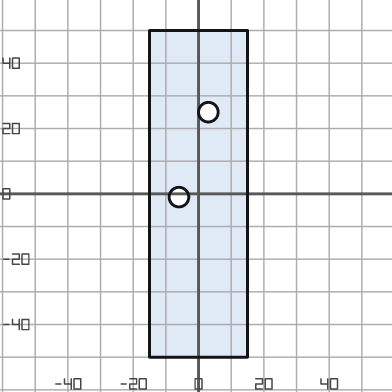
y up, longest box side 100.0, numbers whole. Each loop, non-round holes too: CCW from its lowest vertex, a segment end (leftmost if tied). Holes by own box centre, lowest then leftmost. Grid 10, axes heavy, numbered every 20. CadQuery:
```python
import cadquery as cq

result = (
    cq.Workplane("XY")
    .moveTo(-15.0, -50.0)
    .lineTo(15.0, -50.0)
    .lineTo(15.0, 50.0)
    .lineTo(-15.0, 50.0)
    .close()
    .moveTo(-6.0, -1.0)
    .circle(3.0)
    .moveTo(3.0, 25.0)
    .circle(3.0)
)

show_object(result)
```